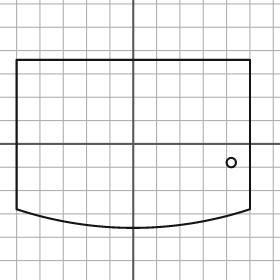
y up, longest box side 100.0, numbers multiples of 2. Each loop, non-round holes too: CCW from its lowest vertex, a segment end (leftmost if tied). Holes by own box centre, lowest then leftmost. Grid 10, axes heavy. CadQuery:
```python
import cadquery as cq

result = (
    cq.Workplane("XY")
    .moveTo(-50.0, -28.0)
    .threePointArc((0.0, -36.0), (50.0, -28.0))
    .lineTo(50.0, 36.0)
    .lineTo(-50.0, 36.0)
    .close()
    .moveTo(42.0, -8.0)
    .circle(2.0)
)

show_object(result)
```